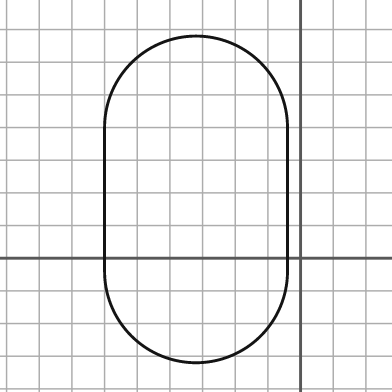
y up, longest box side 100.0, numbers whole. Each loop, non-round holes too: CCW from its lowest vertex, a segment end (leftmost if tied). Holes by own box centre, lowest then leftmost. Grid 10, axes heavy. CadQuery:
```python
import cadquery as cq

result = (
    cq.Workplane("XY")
    .moveTo(-60.0, -4.0)
    .threePointArc((-32.0, -32.0), (-4.0, -4.0))
    .lineTo(-4.0, 40.0)
    .threePointArc((-32.0, 68.0), (-60.0, 40.0))
    .close()
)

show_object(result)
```